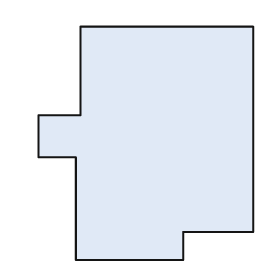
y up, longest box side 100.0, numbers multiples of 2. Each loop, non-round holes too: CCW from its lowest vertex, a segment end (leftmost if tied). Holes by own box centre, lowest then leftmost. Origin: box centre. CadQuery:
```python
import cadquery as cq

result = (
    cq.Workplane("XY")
    .moveTo(-30.0, -50.0)
    .lineTo(16.0, -50.0)
    .lineTo(16.0, -38.0)
    .lineTo(46.0, -38.0)
    .lineTo(46.0, 50.0)
    .lineTo(-28.0, 50.0)
    .lineTo(-28.0, 12.0)
    .lineTo(-46.0, 12.0)
    .lineTo(-46.0, -6.0)
    .lineTo(-30.0, -6.0)
    .close()
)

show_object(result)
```